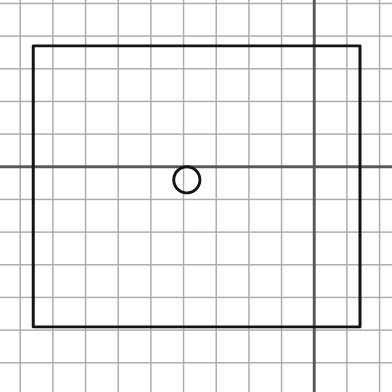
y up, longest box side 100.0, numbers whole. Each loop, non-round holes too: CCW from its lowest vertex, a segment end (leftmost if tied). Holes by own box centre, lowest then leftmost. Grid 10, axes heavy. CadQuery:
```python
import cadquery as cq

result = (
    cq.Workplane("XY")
    .moveTo(-86.0, -49.0)
    .lineTo(14.0, -49.0)
    .lineTo(14.0, 37.0)
    .lineTo(-86.0, 37.0)
    .close()
    .moveTo(-39.0, -4.0)
    .circle(4.0)
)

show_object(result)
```